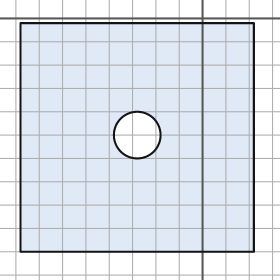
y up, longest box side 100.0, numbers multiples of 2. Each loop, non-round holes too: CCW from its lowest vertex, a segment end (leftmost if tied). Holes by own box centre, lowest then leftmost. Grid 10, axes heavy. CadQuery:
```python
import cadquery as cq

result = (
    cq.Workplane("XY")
    .moveTo(-78.0, -100.0)
    .lineTo(22.0, -100.0)
    .lineTo(22.0, -2.0)
    .lineTo(-78.0, -2.0)
    .close()
    .moveTo(-28.0, -50.0)
    .circle(10.0)
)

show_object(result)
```